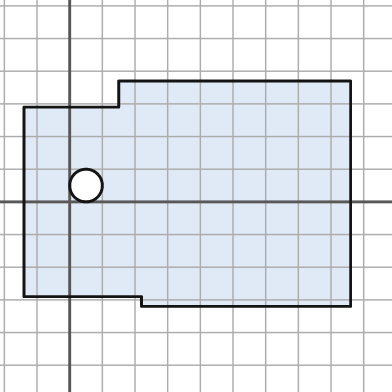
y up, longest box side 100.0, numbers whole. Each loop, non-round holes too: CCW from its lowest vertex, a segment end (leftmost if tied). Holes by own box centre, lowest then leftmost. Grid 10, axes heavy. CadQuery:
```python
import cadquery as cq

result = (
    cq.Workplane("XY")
    .moveTo(22.0, -32.0)
    .lineTo(86.0, -32.0)
    .lineTo(86.0, 37.0)
    .lineTo(15.0, 37.0)
    .lineTo(15.0, 29.0)
    .lineTo(-14.0, 29.0)
    .lineTo(-14.0, -29.0)
    .lineTo(22.0, -29.0)
    .close()
    .moveTo(5.0, 5.0)
    .circle(5.0)
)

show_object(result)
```